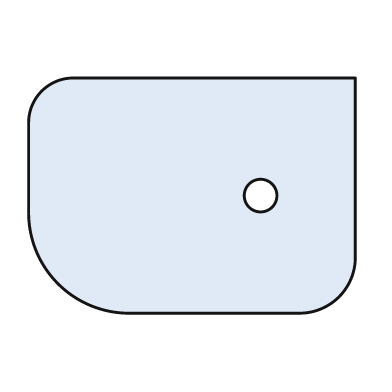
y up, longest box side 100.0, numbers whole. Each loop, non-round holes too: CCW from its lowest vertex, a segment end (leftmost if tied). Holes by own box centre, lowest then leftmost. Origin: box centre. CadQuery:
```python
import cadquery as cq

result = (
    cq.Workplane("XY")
    .moveTo(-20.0, -36.0)
    .lineTo(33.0, -36.0)
    .threePointArc((45.0, -31.0), (50.0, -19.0))
    .lineTo(50.0, 36.0)
    .lineTo(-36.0, 36.0)
    .threePointArc((-46.0, 32.0), (-50.0, 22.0))
    .lineTo(-50.0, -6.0)
    .threePointArc((-41.0, -27.0), (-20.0, -36.0))
    .close()
    .moveTo(21.0, 0.0)
    .circle(5.0)
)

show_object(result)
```